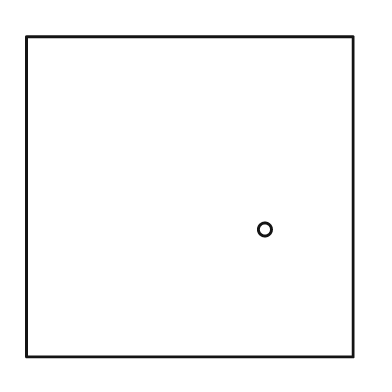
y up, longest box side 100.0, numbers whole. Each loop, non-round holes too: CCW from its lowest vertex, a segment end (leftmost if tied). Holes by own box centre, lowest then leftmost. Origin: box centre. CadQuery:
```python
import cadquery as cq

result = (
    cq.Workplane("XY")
    .moveTo(-50.0, -49.0)
    .lineTo(50.0, -49.0)
    .lineTo(50.0, 49.0)
    .lineTo(-50.0, 49.0)
    .close()
    .moveTo(23.0, -10.0)
    .circle(2.0)
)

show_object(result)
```